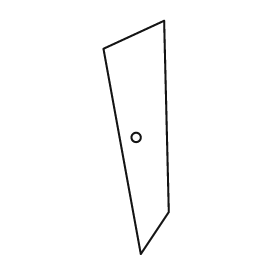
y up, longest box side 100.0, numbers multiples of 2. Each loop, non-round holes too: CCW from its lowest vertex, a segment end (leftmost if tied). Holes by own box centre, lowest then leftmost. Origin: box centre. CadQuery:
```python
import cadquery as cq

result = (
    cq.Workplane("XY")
    .moveTo(2.0, -50.0)
    .lineTo(14.0, -32.0)
    .lineTo(12.0, 50.0)
    .lineTo(-14.0, 38.0)
    .close()
    .moveTo(0.0, 0.0)
    .circle(2.0)
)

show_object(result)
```